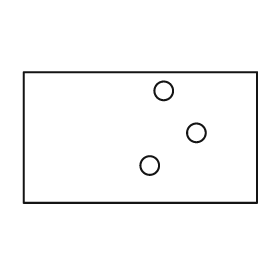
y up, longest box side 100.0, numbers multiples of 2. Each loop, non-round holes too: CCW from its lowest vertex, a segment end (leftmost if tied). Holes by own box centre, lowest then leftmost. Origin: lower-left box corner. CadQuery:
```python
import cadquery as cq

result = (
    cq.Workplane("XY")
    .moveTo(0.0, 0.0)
    .lineTo(100.0, 0.0)
    .lineTo(100.0, 56.0)
    .lineTo(0.0, 56.0)
    .close()
    .moveTo(54.0, 16.0)
    .circle(4.0)
    .moveTo(74.0, 30.0)
    .circle(4.0)
    .moveTo(60.0, 48.0)
    .circle(4.0)
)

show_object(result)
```